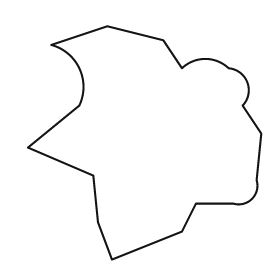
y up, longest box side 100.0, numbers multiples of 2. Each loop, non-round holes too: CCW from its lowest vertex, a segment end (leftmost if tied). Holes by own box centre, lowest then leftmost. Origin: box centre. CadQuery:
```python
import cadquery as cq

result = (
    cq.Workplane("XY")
    .moveTo(-14.0, -50.0)
    .lineTo(16.0, -38.0)
    .lineTo(22.0, -26.0)
    .lineTo(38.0, -26.0)
    .threePointArc((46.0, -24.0), (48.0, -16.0))
    .lineTo(50.0, 4.0)
    .lineTo(42.0, 16.0)
    .threePointArc((44.0, 26.0), (36.0, 32.0))
    .threePointArc((26.0, 36.0), (16.0, 32.0))
    .lineTo(8.0, 44.0)
    .lineTo(-16.0, 50.0)
    .lineTo(-40.0, 42.0)
    .threePointArc((-28.0, 32.0), (-28.0, 16.0))
    .lineTo(-50.0, -2.0)
    .lineTo(-22.0, -14.0)
    .lineTo(-20.0, -34.0)
    .close()
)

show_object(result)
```